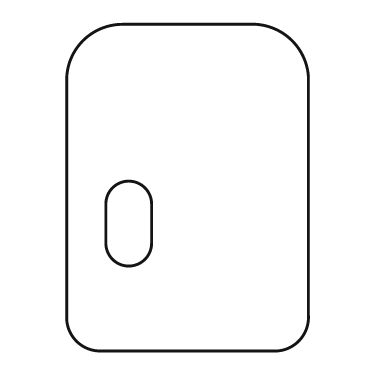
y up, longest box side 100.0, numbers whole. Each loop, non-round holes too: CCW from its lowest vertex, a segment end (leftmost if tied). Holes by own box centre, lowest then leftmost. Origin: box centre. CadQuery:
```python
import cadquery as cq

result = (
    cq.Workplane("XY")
    .moveTo(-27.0, -50.0)
    .lineTo(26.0, -50.0)
    .threePointArc((34.0, -47.0), (37.0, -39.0))
    .lineTo(37.0, 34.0)
    .threePointArc((32.0, 45.0), (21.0, 50.0))
    .lineTo(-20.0, 50.0)
    .threePointArc((-32.0, 45.0), (-37.0, 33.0))
    .lineTo(-37.0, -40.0)
    .threePointArc((-34.0, -47.0), (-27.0, -50.0))
    .close()
    .moveTo(-25.0, -17.0)
    .threePointArc((-18.0, -24.0), (-11.0, -17.0))
    .lineTo(-11.0, -5.0)
    .threePointArc((-18.0, 2.0), (-25.0, -5.0))
    .close()
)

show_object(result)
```